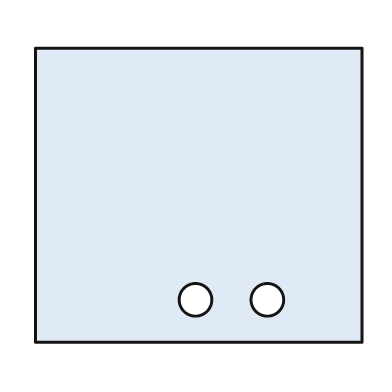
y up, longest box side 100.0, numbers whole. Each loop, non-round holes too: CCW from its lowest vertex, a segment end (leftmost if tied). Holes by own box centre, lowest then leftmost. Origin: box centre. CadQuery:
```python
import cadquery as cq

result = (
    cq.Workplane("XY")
    .moveTo(-50.0, -45.0)
    .lineTo(50.0, -45.0)
    .lineTo(50.0, 45.0)
    .lineTo(-50.0, 45.0)
    .close()
    .moveTo(-1.0, -32.0)
    .circle(5.0)
    .moveTo(21.0, -32.0)
    .circle(5.0)
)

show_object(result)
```